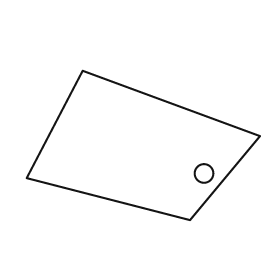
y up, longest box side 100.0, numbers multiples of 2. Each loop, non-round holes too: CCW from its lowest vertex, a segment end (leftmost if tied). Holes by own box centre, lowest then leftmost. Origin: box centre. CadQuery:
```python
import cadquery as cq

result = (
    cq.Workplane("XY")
    .moveTo(20.0, -32.0)
    .lineTo(50.0, 4.0)
    .lineTo(-26.0, 32.0)
    .lineTo(-50.0, -14.0)
    .close()
    .moveTo(26.0, -12.0)
    .circle(4.0)
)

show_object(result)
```